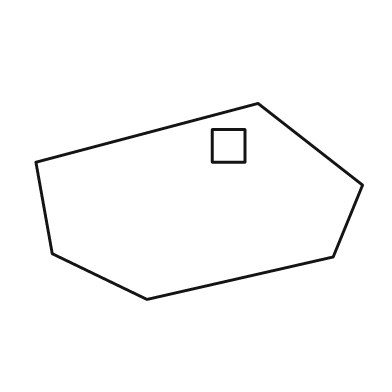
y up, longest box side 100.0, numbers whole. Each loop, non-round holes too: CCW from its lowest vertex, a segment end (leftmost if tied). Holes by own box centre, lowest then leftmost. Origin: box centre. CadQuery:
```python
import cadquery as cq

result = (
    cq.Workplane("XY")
    .moveTo(-16.0, -30.0)
    .lineTo(41.0, -17.0)
    .lineTo(50.0, 5.0)
    .lineTo(18.0, 30.0)
    .lineTo(-50.0, 12.0)
    .lineTo(-45.0, -16.0)
    .close()
    .moveTo(4.0, 12.0)
    .lineTo(14.0, 12.0)
    .lineTo(14.0, 22.0)
    .lineTo(4.0, 22.0)
    .close()
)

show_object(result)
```